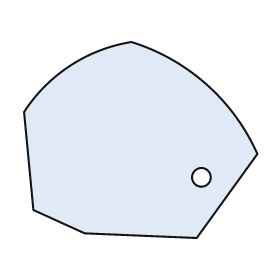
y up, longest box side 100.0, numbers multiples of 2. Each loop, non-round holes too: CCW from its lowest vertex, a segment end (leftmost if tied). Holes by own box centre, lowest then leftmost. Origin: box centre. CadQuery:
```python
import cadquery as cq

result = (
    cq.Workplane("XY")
    .moveTo(24.0, -42.0)
    .lineTo(50.0, -6.0)
    .threePointArc((28.0, 24.0), (-4.0, 42.0))
    .threePointArc((-30.0, 32.0), (-50.0, 12.0))
    .lineTo(-46.0, -30.0)
    .lineTo(-24.0, -40.0)
    .close()
    .moveTo(26.0, -16.0)
    .circle(4.0)
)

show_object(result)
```